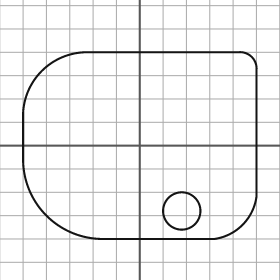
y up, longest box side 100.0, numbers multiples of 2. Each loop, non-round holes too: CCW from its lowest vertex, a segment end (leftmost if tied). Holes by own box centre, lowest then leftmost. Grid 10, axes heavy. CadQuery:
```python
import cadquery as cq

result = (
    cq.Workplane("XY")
    .moveTo(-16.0, -40.0)
    .lineTo(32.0, -40.0)
    .threePointArc((44.0, -34.0), (50.0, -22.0))
    .lineTo(50.0, 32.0)
    .threePointArc((48.0, 38.0), (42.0, 40.0))
    .lineTo(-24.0, 40.0)
    .threePointArc((-42.0, 32.0), (-50.0, 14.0))
    .lineTo(-50.0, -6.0)
    .threePointArc((-40.0, -30.0), (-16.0, -40.0))
    .close()
    .moveTo(18.0, -28.0)
    .circle(8.0)
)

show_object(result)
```